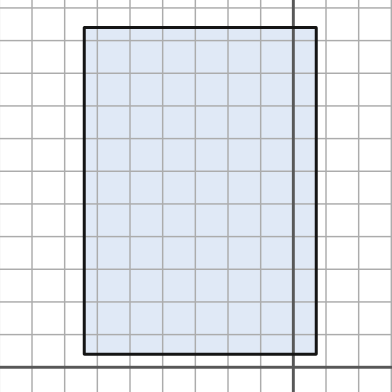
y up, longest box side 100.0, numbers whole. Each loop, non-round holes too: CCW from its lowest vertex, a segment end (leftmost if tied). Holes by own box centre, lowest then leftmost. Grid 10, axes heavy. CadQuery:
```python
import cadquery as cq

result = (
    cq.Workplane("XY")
    .moveTo(-64.0, 4.0)
    .lineTo(7.0, 4.0)
    .lineTo(7.0, 104.0)
    .lineTo(-64.0, 104.0)
    .close()
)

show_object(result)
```